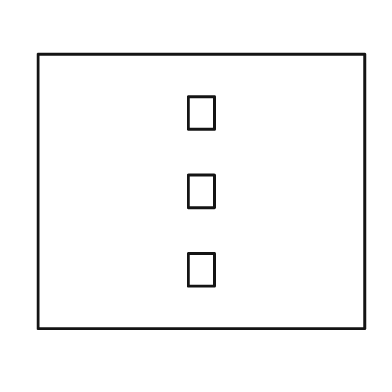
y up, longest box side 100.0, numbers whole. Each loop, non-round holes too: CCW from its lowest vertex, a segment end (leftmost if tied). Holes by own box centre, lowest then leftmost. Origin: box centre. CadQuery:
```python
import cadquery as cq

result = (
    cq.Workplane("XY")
    .moveTo(-50.0, -42.0)
    .lineTo(50.0, -42.0)
    .lineTo(50.0, 42.0)
    .lineTo(-50.0, 42.0)
    .close()
    .moveTo(-4.0, -29.0)
    .lineTo(4.0, -29.0)
    .lineTo(4.0, -19.0)
    .lineTo(-4.0, -19.0)
    .close()
    .moveTo(-4.0, -5.0)
    .lineTo(4.0, -5.0)
    .lineTo(4.0, 5.0)
    .lineTo(-4.0, 5.0)
    .close()
    .moveTo(-4.0, 19.0)
    .lineTo(4.0, 19.0)
    .lineTo(4.0, 29.0)
    .lineTo(-4.0, 29.0)
    .close()
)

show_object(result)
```